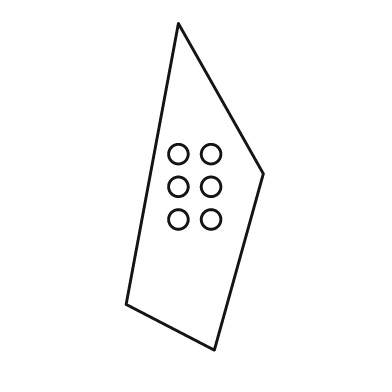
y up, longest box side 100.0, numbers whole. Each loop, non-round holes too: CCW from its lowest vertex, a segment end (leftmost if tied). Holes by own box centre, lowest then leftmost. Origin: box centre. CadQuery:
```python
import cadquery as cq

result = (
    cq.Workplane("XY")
    .moveTo(6.0, -50.0)
    .lineTo(21.0, 4.0)
    .lineTo(-5.0, 50.0)
    .lineTo(-21.0, -36.0)
    .close()
    .moveTo(-5.0, -10.0)
    .circle(3.0)
    .moveTo(5.0, -10.0)
    .circle(3.0)
    .moveTo(-5.0, 0.0)
    .circle(3.0)
    .moveTo(5.0, 0.0)
    .circle(3.0)
    .moveTo(-5.0, 10.0)
    .circle(3.0)
    .moveTo(5.0, 10.0)
    .circle(3.0)
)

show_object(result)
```